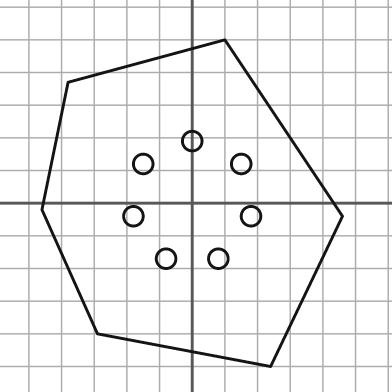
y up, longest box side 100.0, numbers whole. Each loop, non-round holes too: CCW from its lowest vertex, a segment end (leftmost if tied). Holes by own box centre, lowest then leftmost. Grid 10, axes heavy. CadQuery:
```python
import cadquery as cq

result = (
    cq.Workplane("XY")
    .moveTo(24.0, -50.0)
    .lineTo(46.0, -4.0)
    .lineTo(10.0, 50.0)
    .lineTo(-38.0, 37.0)
    .lineTo(-46.0, -2.0)
    .lineTo(-29.0, -40.0)
    .close()
    .moveTo(-8.0, -17.0)
    .circle(3.0)
    .moveTo(8.0, -17.0)
    .circle(3.0)
    .moveTo(-18.0, -4.0)
    .circle(3.0)
    .moveTo(18.0, -4.0)
    .circle(3.0)
    .moveTo(-15.0, 12.0)
    .circle(3.0)
    .moveTo(15.0, 12.0)
    .circle(3.0)
    .moveTo(0.0, 19.0)
    .circle(3.0)
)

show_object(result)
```